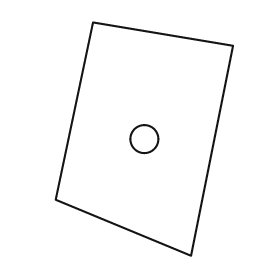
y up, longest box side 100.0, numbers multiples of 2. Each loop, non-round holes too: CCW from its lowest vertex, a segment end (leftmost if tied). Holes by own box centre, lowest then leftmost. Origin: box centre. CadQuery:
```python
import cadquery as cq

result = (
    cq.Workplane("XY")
    .moveTo(20.0, -50.0)
    .lineTo(38.0, 40.0)
    .lineTo(-22.0, 50.0)
    .lineTo(-38.0, -26.0)
    .close()
    .moveTo(0.0, 0.0)
    .circle(6.0)
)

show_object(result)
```